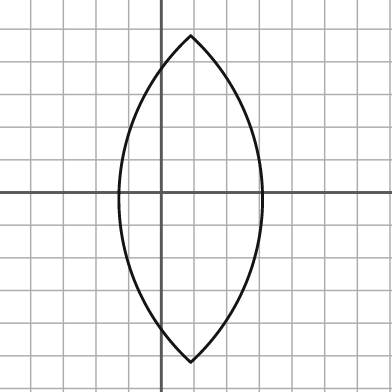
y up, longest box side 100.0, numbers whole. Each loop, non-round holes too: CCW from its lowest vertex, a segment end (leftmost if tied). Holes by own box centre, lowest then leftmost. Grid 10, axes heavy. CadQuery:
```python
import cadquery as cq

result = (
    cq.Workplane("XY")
    .moveTo(9.0, -52.0)
    .threePointArc((31.0, -2.0), (9.0, 48.0))
    .threePointArc((-13.0, -2.0), (9.0, -52.0))
    .close()
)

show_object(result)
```